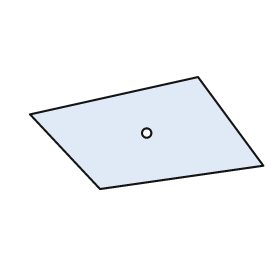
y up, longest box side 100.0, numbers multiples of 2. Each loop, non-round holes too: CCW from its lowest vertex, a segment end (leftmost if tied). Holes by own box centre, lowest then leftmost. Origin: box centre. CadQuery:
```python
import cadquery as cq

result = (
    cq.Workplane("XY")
    .moveTo(-20.0, -24.0)
    .lineTo(50.0, -14.0)
    .lineTo(22.0, 24.0)
    .lineTo(-50.0, 8.0)
    .close()
    .moveTo(0.0, 0.0)
    .circle(2.0)
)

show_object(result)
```